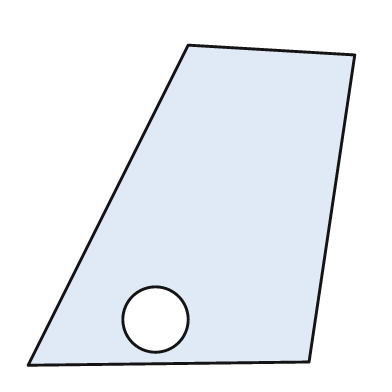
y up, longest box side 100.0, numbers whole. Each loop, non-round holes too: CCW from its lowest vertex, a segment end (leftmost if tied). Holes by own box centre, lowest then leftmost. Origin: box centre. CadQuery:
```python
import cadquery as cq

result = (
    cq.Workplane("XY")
    .moveTo(-50.0, -49.0)
    .lineTo(36.0, -48.0)
    .lineTo(50.0, 46.0)
    .lineTo(-1.0, 49.0)
    .close()
    .moveTo(-11.0, -35.0)
    .circle(10.0)
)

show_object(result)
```